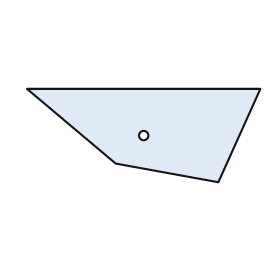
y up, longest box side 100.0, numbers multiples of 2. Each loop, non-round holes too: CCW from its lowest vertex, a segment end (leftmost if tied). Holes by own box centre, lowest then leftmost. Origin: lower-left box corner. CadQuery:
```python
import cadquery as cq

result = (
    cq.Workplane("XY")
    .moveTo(82.0, 0.0)
    .lineTo(100.0, 40.0)
    .lineTo(0.0, 40.0)
    .lineTo(38.0, 8.0)
    .close()
    .moveTo(50.0, 20.0)
    .circle(2.0)
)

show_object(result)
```